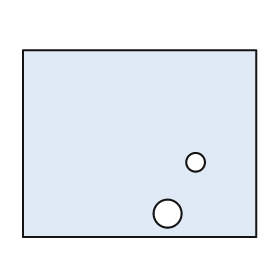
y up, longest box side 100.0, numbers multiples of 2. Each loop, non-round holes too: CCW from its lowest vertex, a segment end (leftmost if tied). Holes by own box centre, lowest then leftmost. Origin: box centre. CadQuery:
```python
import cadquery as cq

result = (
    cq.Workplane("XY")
    .moveTo(-50.0, -40.0)
    .lineTo(50.0, -40.0)
    .lineTo(50.0, 40.0)
    .lineTo(-50.0, 40.0)
    .close()
    .moveTo(12.0, -30.0)
    .circle(6.0)
    .moveTo(24.0, -8.0)
    .circle(4.0)
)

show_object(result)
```